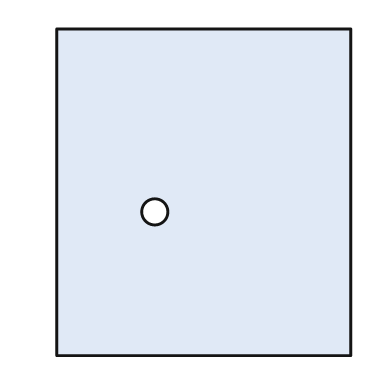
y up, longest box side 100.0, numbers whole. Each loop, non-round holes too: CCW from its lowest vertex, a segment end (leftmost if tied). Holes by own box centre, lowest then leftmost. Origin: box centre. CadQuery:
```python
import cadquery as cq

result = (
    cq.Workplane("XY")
    .moveTo(-45.0, -50.0)
    .lineTo(45.0, -50.0)
    .lineTo(45.0, 50.0)
    .lineTo(-45.0, 50.0)
    .close()
    .moveTo(-15.0, -6.0)
    .circle(4.0)
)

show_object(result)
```